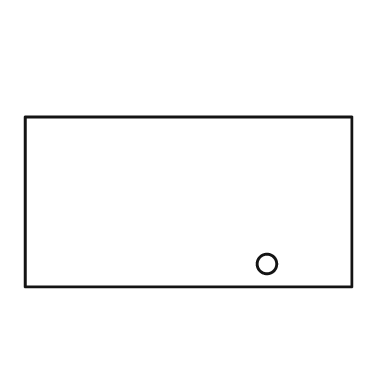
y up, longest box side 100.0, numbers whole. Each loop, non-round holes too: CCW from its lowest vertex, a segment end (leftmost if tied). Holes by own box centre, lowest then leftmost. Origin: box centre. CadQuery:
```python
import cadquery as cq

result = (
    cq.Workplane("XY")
    .moveTo(-50.0, -26.0)
    .lineTo(50.0, -26.0)
    .lineTo(50.0, 26.0)
    .lineTo(-50.0, 26.0)
    .close()
    .moveTo(24.0, -19.0)
    .circle(3.0)
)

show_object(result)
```